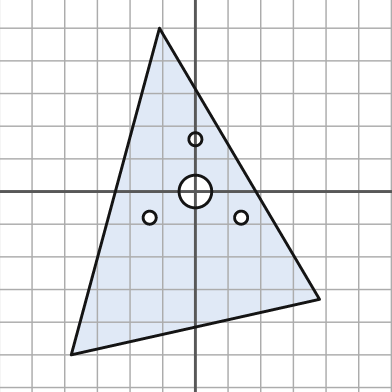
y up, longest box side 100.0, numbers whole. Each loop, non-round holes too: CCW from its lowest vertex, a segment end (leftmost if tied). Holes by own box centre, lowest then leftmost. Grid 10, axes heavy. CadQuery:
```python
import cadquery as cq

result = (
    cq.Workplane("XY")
    .moveTo(-38.0, -50.0)
    .lineTo(38.0, -33.0)
    .lineTo(-11.0, 50.0)
    .close()
    .moveTo(-14.0, -8.0)
    .circle(2.0)
    .moveTo(14.0, -8.0)
    .circle(2.0)
    .moveTo(0.0, 0.0)
    .circle(5.0)
    .moveTo(0.0, 16.0)
    .circle(2.0)
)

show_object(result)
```